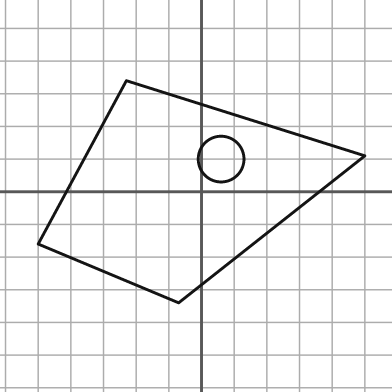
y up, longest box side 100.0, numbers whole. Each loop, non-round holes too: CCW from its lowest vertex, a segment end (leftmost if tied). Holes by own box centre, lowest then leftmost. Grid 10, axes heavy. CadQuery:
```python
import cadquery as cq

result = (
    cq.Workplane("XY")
    .moveTo(-7.0, -34.0)
    .lineTo(50.0, 11.0)
    .lineTo(-23.0, 34.0)
    .lineTo(-50.0, -16.0)
    .close()
    .moveTo(6.0, 10.0)
    .circle(7.0)
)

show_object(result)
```